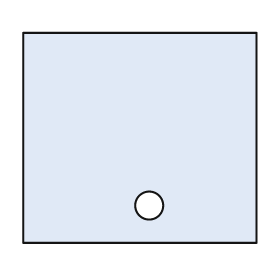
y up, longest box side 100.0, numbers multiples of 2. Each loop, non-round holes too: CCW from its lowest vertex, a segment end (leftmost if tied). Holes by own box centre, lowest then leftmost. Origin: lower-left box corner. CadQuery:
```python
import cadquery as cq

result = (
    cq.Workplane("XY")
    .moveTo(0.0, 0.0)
    .lineTo(100.0, 0.0)
    .lineTo(100.0, 90.0)
    .lineTo(0.0, 90.0)
    .close()
    .moveTo(54.0, 16.0)
    .circle(6.0)
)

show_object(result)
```